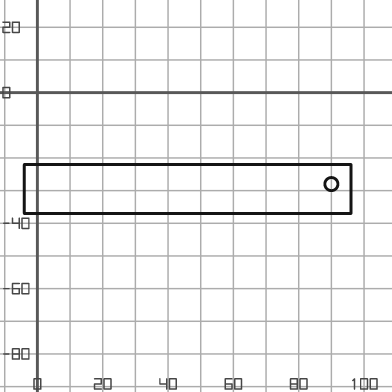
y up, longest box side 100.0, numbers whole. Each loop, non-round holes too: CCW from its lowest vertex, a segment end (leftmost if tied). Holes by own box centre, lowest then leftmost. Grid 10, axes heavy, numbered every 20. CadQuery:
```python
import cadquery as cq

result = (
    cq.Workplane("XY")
    .moveTo(-4.0, -37.0)
    .lineTo(96.0, -37.0)
    .lineTo(96.0, -22.0)
    .lineTo(-4.0, -22.0)
    .close()
    .moveTo(90.0, -28.0)
    .circle(2.0)
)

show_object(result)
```